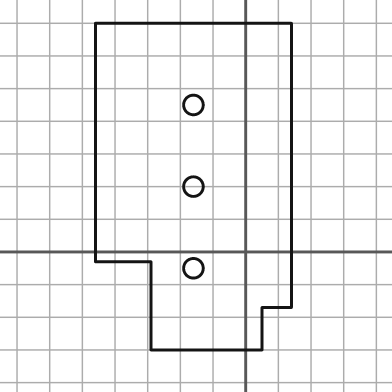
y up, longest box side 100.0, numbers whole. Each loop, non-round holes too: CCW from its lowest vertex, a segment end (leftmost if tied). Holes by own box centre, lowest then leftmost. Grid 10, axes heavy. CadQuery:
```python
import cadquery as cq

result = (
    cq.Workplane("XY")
    .moveTo(-29.0, -30.0)
    .lineTo(5.0, -30.0)
    .lineTo(5.0, -17.0)
    .lineTo(14.0, -17.0)
    .lineTo(14.0, 70.0)
    .lineTo(-46.0, 70.0)
    .lineTo(-46.0, -3.0)
    .lineTo(-29.0, -3.0)
    .close()
    .moveTo(-16.0, -5.0)
    .circle(3.0)
    .moveTo(-16.0, 20.0)
    .circle(3.0)
    .moveTo(-16.0, 45.0)
    .circle(3.0)
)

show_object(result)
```